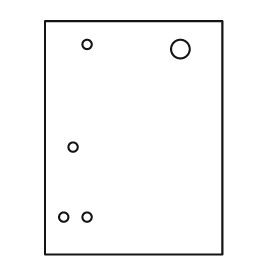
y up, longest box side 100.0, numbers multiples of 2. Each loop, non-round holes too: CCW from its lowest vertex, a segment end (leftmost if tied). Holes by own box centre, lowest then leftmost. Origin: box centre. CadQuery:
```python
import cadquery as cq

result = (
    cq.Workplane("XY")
    .moveTo(-38.0, -50.0)
    .lineTo(38.0, -50.0)
    .lineTo(38.0, 50.0)
    .lineTo(-38.0, 50.0)
    .close()
    .moveTo(-30.0, -34.0)
    .circle(2.0)
    .moveTo(-20.0, -34.0)
    .circle(2.0)
    .moveTo(-26.0, -4.0)
    .circle(2.0)
    .moveTo(20.0, 38.0)
    .circle(4.0)
    .moveTo(-20.0, 40.0)
    .circle(2.0)
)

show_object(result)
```